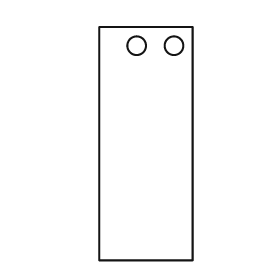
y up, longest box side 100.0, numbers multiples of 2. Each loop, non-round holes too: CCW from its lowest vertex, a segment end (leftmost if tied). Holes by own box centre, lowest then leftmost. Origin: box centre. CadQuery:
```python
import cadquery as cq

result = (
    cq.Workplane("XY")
    .moveTo(-20.0, -50.0)
    .lineTo(20.0, -50.0)
    .lineTo(20.0, 50.0)
    .lineTo(-20.0, 50.0)
    .close()
    .moveTo(-4.0, 42.0)
    .circle(4.0)
    .moveTo(12.0, 42.0)
    .circle(4.0)
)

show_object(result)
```